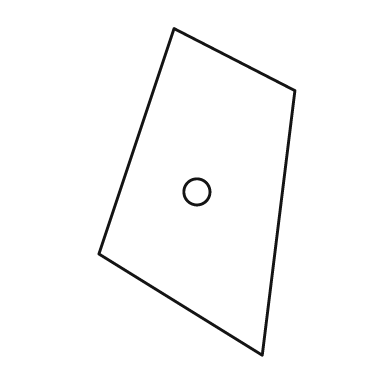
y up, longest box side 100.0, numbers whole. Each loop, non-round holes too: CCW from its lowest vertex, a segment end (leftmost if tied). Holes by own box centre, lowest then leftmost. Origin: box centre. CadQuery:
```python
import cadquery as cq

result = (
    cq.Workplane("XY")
    .moveTo(20.0, -50.0)
    .lineTo(30.0, 31.0)
    .lineTo(-7.0, 50.0)
    .lineTo(-30.0, -19.0)
    .close()
    .moveTo(0.0, 0.0)
    .circle(4.0)
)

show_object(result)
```